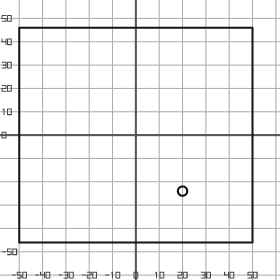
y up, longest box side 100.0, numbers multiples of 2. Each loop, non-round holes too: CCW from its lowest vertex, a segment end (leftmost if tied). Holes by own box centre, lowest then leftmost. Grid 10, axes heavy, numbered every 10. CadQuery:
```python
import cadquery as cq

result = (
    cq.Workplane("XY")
    .moveTo(-50.0, -46.0)
    .lineTo(50.0, -46.0)
    .lineTo(50.0, 46.0)
    .lineTo(-50.0, 46.0)
    .close()
    .moveTo(20.0, -24.0)
    .circle(2.0)
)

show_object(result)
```